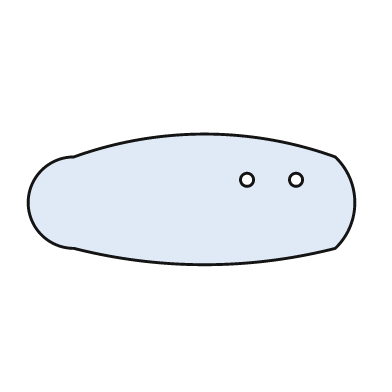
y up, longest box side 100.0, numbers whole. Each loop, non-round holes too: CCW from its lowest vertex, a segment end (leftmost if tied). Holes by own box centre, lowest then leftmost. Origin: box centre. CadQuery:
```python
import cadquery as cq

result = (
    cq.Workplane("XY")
    .moveTo(-36.0, -15.0)
    .threePointArc((4.0, -20.0), (44.0, -15.0))
    .threePointArc((50.0, -1.0), (44.0, 13.0))
    .threePointArc((4.0, 20.0), (-36.0, 13.0))
    .threePointArc((-50.0, -1.0), (-36.0, -15.0))
    .close()
    .moveTo(17.0, 6.0)
    .circle(2.0)
    .moveTo(32.0, 6.0)
    .circle(2.0)
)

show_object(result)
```